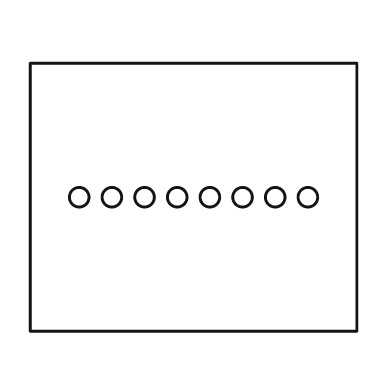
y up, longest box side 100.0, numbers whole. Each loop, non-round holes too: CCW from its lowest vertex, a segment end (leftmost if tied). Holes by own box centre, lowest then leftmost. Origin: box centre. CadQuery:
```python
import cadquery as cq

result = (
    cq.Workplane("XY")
    .moveTo(-50.0, -41.0)
    .lineTo(50.0, -41.0)
    .lineTo(50.0, 41.0)
    .lineTo(-50.0, 41.0)
    .close()
    .moveTo(-35.0, 0.0)
    .circle(3.0)
    .moveTo(-25.0, 0.0)
    .circle(3.0)
    .moveTo(-15.0, 0.0)
    .circle(3.0)
    .moveTo(-5.0, 0.0)
    .circle(3.0)
    .moveTo(5.0, 0.0)
    .circle(3.0)
    .moveTo(15.0, 0.0)
    .circle(3.0)
    .moveTo(25.0, 0.0)
    .circle(3.0)
    .moveTo(35.0, 0.0)
    .circle(3.0)
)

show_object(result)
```